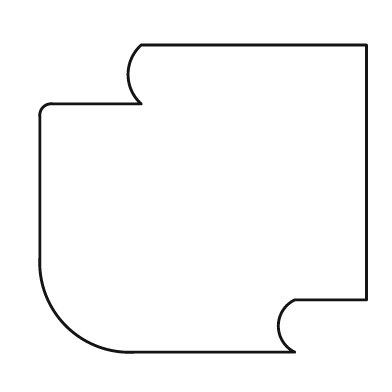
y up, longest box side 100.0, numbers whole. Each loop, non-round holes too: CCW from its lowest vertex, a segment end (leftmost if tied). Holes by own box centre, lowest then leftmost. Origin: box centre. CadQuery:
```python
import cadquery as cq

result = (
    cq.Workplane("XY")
    .moveTo(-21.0, -47.0)
    .lineTo(28.0, -47.0)
    .threePointArc((23.0, -39.0), (28.0, -31.0))
    .lineTo(50.0, -31.0)
    .lineTo(50.0, 47.0)
    .lineTo(-19.0, 47.0)
    .threePointArc((-23.0, 38.0), (-19.0, 29.0))
    .lineTo(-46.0, 29.0)
    .threePointArc((-49.0, 28.0), (-50.0, 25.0))
    .lineTo(-50.0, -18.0)
    .threePointArc((-42.0, -39.0), (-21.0, -47.0))
    .close()
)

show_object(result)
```